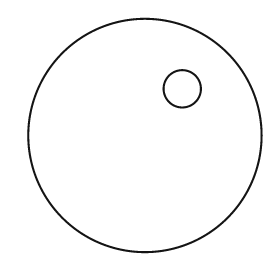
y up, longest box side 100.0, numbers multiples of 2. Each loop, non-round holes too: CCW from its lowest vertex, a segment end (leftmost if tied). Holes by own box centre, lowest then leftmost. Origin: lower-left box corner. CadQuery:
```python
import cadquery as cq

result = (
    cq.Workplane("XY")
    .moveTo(50.0, 50.0)
    .circle(50.0)
    .moveTo(66.0, 70.0)
    .circle(8.0)
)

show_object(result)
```